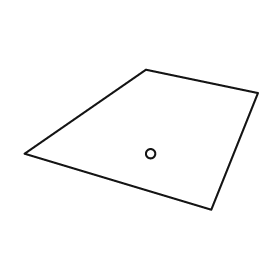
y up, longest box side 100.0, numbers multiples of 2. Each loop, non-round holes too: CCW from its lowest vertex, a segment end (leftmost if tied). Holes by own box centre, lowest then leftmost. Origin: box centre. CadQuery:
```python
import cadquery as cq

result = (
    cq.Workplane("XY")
    .moveTo(30.0, -30.0)
    .lineTo(50.0, 20.0)
    .lineTo(2.0, 30.0)
    .lineTo(-50.0, -6.0)
    .close()
    .moveTo(4.0, -6.0)
    .circle(2.0)
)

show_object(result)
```